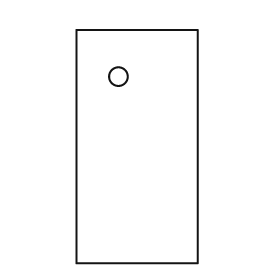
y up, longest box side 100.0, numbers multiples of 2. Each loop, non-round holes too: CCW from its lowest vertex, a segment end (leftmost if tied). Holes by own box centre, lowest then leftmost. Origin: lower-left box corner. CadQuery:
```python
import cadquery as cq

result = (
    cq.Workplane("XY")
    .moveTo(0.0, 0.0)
    .lineTo(52.0, 0.0)
    .lineTo(52.0, 100.0)
    .lineTo(0.0, 100.0)
    .close()
    .moveTo(18.0, 80.0)
    .circle(4.0)
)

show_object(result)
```